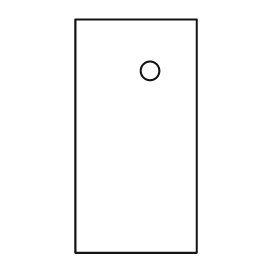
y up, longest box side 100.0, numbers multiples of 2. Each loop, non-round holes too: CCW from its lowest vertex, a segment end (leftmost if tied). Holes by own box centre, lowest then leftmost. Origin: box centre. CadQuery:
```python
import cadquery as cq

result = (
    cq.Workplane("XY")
    .moveTo(-26.0, -50.0)
    .lineTo(26.0, -50.0)
    .lineTo(26.0, 50.0)
    .lineTo(-26.0, 50.0)
    .close()
    .moveTo(6.0, 28.0)
    .circle(4.0)
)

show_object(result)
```